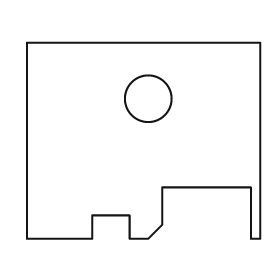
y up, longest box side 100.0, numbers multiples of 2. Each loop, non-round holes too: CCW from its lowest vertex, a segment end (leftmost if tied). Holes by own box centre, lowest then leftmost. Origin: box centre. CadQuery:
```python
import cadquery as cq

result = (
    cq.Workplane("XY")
    .moveTo(-50.0, -42.0)
    .lineTo(-22.0, -42.0)
    .lineTo(-22.0, -32.0)
    .lineTo(-6.0, -32.0)
    .lineTo(-6.0, -42.0)
    .lineTo(2.0, -42.0)
    .lineTo(8.0, -36.0)
    .lineTo(8.0, -20.0)
    .lineTo(46.0, -20.0)
    .lineTo(46.0, -42.0)
    .lineTo(50.0, -42.0)
    .lineTo(50.0, 42.0)
    .lineTo(-50.0, 42.0)
    .close()
    .moveTo(2.0, 18.0)
    .circle(10.0)
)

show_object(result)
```